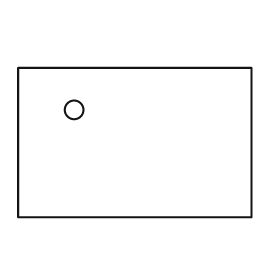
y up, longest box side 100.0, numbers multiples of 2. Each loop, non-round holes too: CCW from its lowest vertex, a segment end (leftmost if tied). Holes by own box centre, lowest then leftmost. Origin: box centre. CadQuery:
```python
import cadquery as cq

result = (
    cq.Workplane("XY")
    .moveTo(-50.0, -32.0)
    .lineTo(50.0, -32.0)
    .lineTo(50.0, 32.0)
    .lineTo(-50.0, 32.0)
    .close()
    .moveTo(-26.0, 14.0)
    .circle(4.0)
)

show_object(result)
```